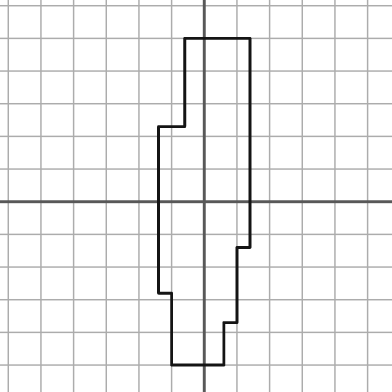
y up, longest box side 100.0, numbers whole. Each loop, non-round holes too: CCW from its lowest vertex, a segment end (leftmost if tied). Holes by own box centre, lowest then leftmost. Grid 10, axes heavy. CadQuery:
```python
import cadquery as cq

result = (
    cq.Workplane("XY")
    .moveTo(-10.0, -50.0)
    .lineTo(6.0, -50.0)
    .lineTo(6.0, -37.0)
    .lineTo(10.0, -37.0)
    .lineTo(10.0, -14.0)
    .lineTo(14.0, -14.0)
    .lineTo(14.0, 50.0)
    .lineTo(-6.0, 50.0)
    .lineTo(-6.0, 23.0)
    .lineTo(-14.0, 23.0)
    .lineTo(-14.0, -28.0)
    .lineTo(-10.0, -28.0)
    .close()
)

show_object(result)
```